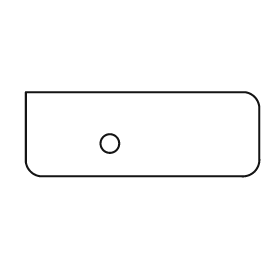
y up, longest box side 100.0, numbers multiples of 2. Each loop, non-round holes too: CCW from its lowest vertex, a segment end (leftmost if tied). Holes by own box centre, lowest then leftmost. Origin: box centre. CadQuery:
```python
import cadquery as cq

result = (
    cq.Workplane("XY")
    .moveTo(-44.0, -18.0)
    .lineTo(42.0, -18.0)
    .threePointArc((48.0, -16.0), (50.0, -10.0))
    .lineTo(50.0, 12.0)
    .threePointArc((48.0, 16.0), (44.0, 18.0))
    .lineTo(-50.0, 18.0)
    .lineTo(-50.0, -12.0)
    .threePointArc((-48.0, -16.0), (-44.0, -18.0))
    .close()
    .moveTo(-14.0, -4.0)
    .circle(4.0)
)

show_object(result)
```